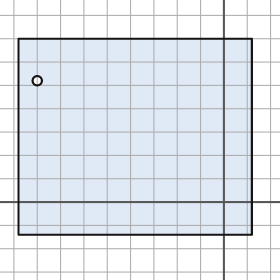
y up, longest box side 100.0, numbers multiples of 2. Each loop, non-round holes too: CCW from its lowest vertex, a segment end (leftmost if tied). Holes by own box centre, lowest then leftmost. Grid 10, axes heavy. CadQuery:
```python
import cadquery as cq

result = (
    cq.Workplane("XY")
    .moveTo(-88.0, -14.0)
    .lineTo(12.0, -14.0)
    .lineTo(12.0, 70.0)
    .lineTo(-88.0, 70.0)
    .close()
    .moveTo(-80.0, 52.0)
    .circle(2.0)
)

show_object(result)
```